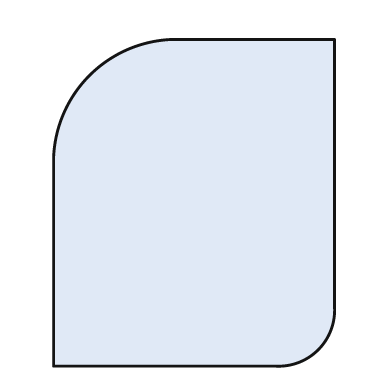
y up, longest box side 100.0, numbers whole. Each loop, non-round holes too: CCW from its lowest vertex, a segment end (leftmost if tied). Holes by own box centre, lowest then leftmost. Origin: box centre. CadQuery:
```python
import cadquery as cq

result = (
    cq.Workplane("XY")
    .moveTo(-43.0, -50.0)
    .lineTo(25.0, -50.0)
    .threePointArc((38.0, -45.0), (43.0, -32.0))
    .lineTo(43.0, 50.0)
    .lineTo(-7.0, 50.0)
    .threePointArc((-32.0, 39.0), (-43.0, 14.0))
    .close()
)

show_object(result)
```